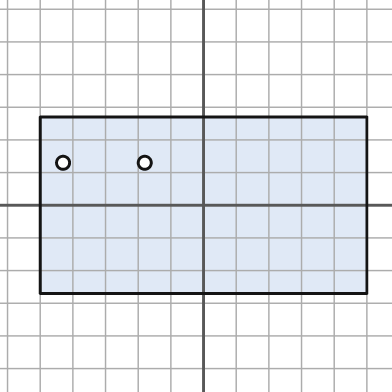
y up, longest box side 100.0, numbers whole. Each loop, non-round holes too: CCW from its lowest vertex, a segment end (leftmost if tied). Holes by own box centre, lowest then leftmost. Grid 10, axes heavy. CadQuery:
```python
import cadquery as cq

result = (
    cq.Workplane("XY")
    .moveTo(-50.0, -27.0)
    .lineTo(50.0, -27.0)
    .lineTo(50.0, 27.0)
    .lineTo(-50.0, 27.0)
    .close()
    .moveTo(-43.0, 13.0)
    .circle(2.0)
    .moveTo(-18.0, 13.0)
    .circle(2.0)
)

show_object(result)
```